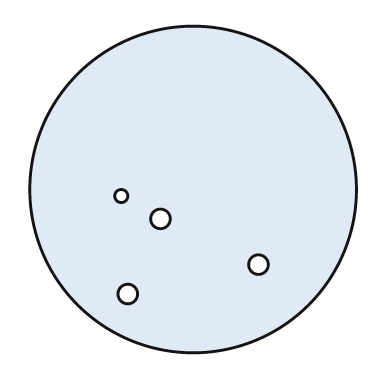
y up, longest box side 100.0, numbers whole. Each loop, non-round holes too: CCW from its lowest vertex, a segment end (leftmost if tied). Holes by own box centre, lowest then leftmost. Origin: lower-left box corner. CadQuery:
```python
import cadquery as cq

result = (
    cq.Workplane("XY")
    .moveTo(50.0, 50.0)
    .circle(50.0)
    .moveTo(30.0, 18.0)
    .circle(3.0)
    .moveTo(70.0, 27.0)
    .circle(3.0)
    .moveTo(40.0, 41.0)
    .circle(3.0)
    .moveTo(28.0, 48.0)
    .circle(2.0)
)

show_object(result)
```